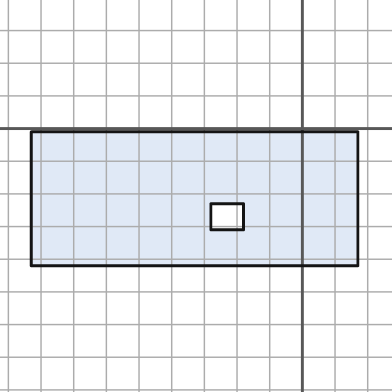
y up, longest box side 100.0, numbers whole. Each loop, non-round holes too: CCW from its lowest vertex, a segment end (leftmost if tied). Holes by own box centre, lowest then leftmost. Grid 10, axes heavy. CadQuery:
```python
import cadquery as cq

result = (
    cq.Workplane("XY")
    .moveTo(-83.0, -42.0)
    .lineTo(17.0, -42.0)
    .lineTo(17.0, -1.0)
    .lineTo(-83.0, -1.0)
    .close()
    .moveTo(-28.0, -31.0)
    .lineTo(-18.0, -31.0)
    .lineTo(-18.0, -23.0)
    .lineTo(-28.0, -23.0)
    .close()
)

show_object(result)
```